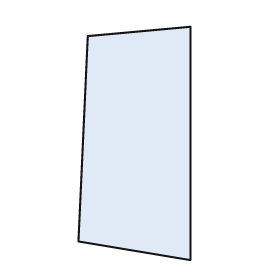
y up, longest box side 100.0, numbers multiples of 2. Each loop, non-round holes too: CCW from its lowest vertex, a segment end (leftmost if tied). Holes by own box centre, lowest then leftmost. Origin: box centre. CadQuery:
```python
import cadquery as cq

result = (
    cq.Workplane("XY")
    .moveTo(24.0, -50.0)
    .lineTo(24.0, 50.0)
    .lineTo(-20.0, 46.0)
    .lineTo(-24.0, -42.0)
    .close()
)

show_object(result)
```